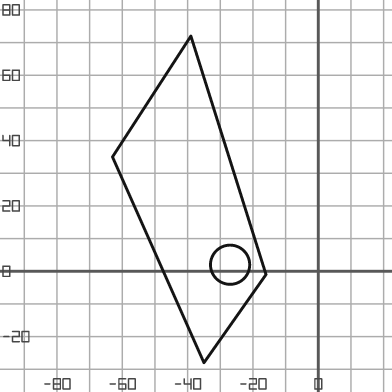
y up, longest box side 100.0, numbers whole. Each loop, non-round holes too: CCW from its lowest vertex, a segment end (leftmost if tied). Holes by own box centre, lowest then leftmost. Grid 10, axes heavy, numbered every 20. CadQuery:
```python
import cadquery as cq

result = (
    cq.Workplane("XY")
    .moveTo(-35.0, -28.0)
    .lineTo(-16.0, -1.0)
    .lineTo(-39.0, 72.0)
    .lineTo(-63.0, 35.0)
    .close()
    .moveTo(-27.0, 2.0)
    .circle(6.0)
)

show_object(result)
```